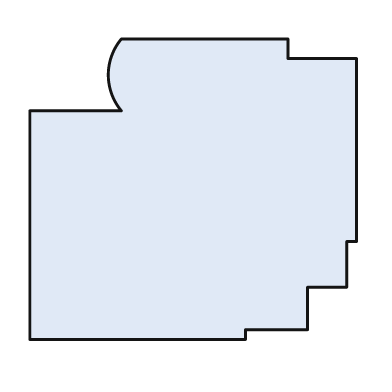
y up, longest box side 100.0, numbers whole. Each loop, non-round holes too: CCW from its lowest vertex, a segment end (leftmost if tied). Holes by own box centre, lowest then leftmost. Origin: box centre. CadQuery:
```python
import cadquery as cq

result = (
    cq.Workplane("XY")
    .moveTo(-50.0, -46.0)
    .lineTo(16.0, -46.0)
    .lineTo(16.0, -43.0)
    .lineTo(35.0, -43.0)
    .lineTo(35.0, -30.0)
    .lineTo(47.0, -30.0)
    .lineTo(47.0, -16.0)
    .lineTo(50.0, -16.0)
    .lineTo(50.0, 40.0)
    .lineTo(29.0, 40.0)
    .lineTo(29.0, 46.0)
    .lineTo(-22.0, 46.0)
    .threePointArc((-26.0, 35.0), (-22.0, 24.0))
    .lineTo(-50.0, 24.0)
    .close()
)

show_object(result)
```